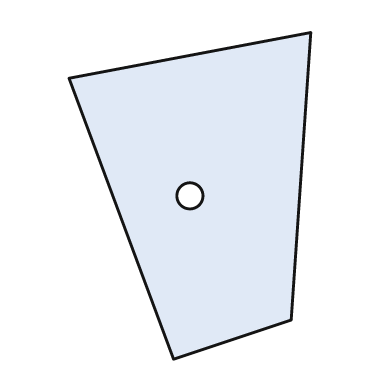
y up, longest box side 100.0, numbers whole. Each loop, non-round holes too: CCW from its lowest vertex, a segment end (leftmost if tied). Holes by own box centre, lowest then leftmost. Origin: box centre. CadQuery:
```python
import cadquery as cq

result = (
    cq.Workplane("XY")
    .moveTo(-5.0, -50.0)
    .lineTo(31.0, -38.0)
    .lineTo(37.0, 50.0)
    .lineTo(-37.0, 36.0)
    .close()
    .moveTo(0.0, 0.0)
    .circle(4.0)
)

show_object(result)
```